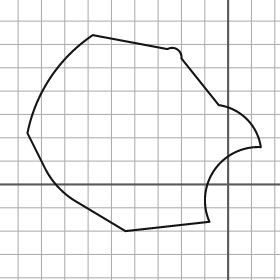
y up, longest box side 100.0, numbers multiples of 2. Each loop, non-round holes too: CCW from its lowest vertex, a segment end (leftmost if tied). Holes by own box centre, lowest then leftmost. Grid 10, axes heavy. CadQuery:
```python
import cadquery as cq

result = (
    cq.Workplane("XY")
    .moveTo(-44.0, -20.0)
    .lineTo(-8.0, -16.0)
    .threePointArc((-6.0, 6.0), (14.0, 16.0))
    .threePointArc((8.0, 28.0), (-4.0, 34.0))
    .lineTo(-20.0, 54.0)
    .threePointArc((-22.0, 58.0), (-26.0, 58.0))
    .lineTo(-58.0, 64.0)
    .threePointArc((-76.0, 46.0), (-86.0, 22.0))
    .lineTo(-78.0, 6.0)
    .threePointArc((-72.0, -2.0), (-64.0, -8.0))
    .close()
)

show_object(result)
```